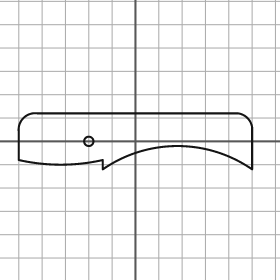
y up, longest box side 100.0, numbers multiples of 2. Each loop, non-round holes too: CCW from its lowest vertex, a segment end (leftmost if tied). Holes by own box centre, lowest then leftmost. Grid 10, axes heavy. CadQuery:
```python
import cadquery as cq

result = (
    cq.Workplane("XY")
    .moveTo(-14.0, -12.0)
    .threePointArc((18.0, -2.0), (50.0, -12.0))
    .lineTo(50.0, 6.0)
    .threePointArc((48.0, 10.0), (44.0, 12.0))
    .lineTo(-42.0, 12.0)
    .threePointArc((-48.0, 10.0), (-50.0, 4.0))
    .lineTo(-50.0, -8.0)
    .threePointArc((-32.0, -10.0), (-14.0, -8.0))
    .close()
    .moveTo(-20.0, 0.0)
    .circle(2.0)
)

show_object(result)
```